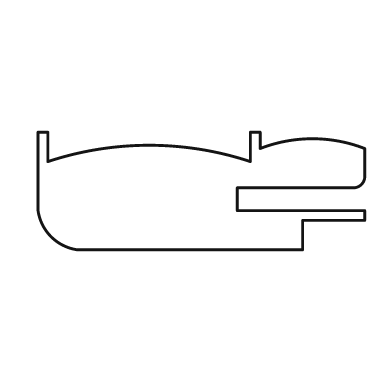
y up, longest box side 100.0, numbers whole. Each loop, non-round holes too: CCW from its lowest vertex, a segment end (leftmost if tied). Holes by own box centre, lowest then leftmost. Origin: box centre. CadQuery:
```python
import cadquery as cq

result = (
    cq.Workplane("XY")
    .moveTo(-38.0, -18.0)
    .lineTo(31.0, -18.0)
    .lineTo(31.0, -9.0)
    .lineTo(50.0, -9.0)
    .lineTo(50.0, -6.0)
    .lineTo(11.0, -6.0)
    .lineTo(11.0, 1.0)
    .lineTo(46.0, 1.0)
    .threePointArc((49.0, 2.0), (50.0, 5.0))
    .lineTo(50.0, 13.0)
    .threePointArc((34.0, 16.0), (18.0, 13.0))
    .lineTo(18.0, 18.0)
    .lineTo(15.0, 18.0)
    .lineTo(15.0, 9.0)
    .threePointArc((-16.0, 14.0), (-47.0, 9.0))
    .lineTo(-47.0, 18.0)
    .lineTo(-50.0, 18.0)
    .lineTo(-50.0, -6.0)
    .threePointArc((-46.0, -14.0), (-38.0, -18.0))
    .close()
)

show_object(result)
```